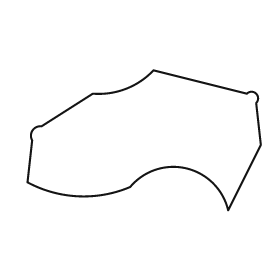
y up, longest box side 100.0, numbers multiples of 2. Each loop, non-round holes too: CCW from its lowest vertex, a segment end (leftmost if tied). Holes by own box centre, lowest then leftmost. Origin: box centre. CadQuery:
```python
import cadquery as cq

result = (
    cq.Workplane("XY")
    .moveTo(36.0, -30.0)
    .lineTo(50.0, -2.0)
    .lineTo(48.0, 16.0)
    .threePointArc((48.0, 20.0), (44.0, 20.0))
    .lineTo(4.0, 30.0)
    .threePointArc((-8.0, 22.0), (-22.0, 20.0))
    .lineTo(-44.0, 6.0)
    .threePointArc((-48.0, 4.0), (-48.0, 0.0))
    .lineTo(-50.0, -18.0)
    .threePointArc((-28.0, -24.0), (-6.0, -20.0))
    .threePointArc((18.0, -12.0), (36.0, -30.0))
    .close()
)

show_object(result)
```